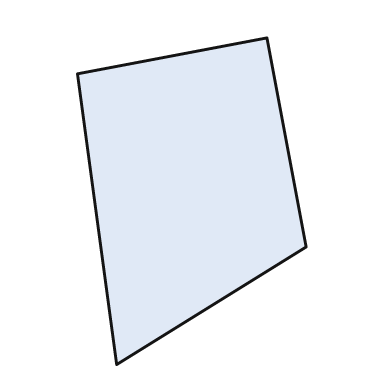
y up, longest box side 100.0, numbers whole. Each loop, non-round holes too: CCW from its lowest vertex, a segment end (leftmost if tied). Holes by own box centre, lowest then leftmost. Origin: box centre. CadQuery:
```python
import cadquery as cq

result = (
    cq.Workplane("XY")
    .moveTo(-23.0, -50.0)
    .lineTo(35.0, -14.0)
    .lineTo(23.0, 50.0)
    .lineTo(-35.0, 39.0)
    .close()
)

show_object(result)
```